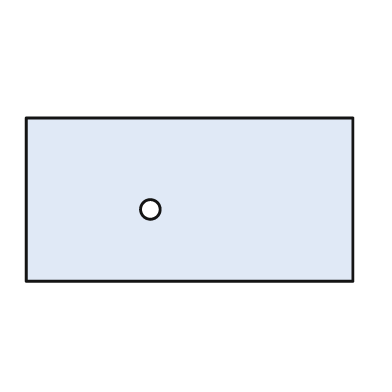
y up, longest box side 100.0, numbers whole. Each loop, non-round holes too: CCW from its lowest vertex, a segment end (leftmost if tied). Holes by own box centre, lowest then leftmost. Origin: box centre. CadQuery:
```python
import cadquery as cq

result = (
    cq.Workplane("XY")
    .moveTo(-50.0, -25.0)
    .lineTo(50.0, -25.0)
    .lineTo(50.0, 25.0)
    .lineTo(-50.0, 25.0)
    .close()
    .moveTo(-12.0, -3.0)
    .circle(3.0)
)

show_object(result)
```